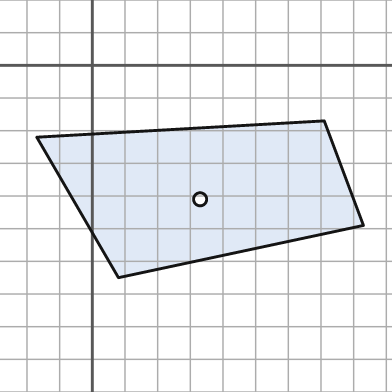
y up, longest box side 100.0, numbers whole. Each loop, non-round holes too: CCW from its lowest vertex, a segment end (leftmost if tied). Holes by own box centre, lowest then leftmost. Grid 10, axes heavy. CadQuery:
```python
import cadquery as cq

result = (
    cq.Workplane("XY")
    .moveTo(8.0, -65.0)
    .lineTo(83.0, -49.0)
    .lineTo(71.0, -17.0)
    .lineTo(-17.0, -22.0)
    .close()
    .moveTo(33.0, -41.0)
    .circle(2.0)
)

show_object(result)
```